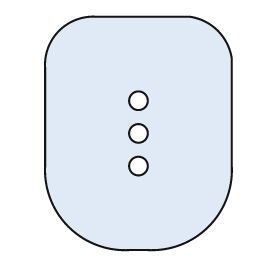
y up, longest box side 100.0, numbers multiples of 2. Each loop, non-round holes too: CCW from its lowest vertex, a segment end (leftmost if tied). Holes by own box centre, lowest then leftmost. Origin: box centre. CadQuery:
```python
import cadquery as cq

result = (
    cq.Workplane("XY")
    .moveTo(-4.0, -50.0)
    .lineTo(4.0, -50.0)
    .threePointArc((30.0, -40.0), (40.0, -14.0))
    .lineTo(40.0, 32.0)
    .threePointArc((34.0, 44.0), (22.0, 50.0))
    .lineTo(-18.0, 50.0)
    .threePointArc((-34.0, 44.0), (-40.0, 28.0))
    .lineTo(-40.0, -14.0)
    .threePointArc((-30.0, -40.0), (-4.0, -50.0))
    .close()
    .moveTo(0.0, -14.0)
    .circle(4.0)
    .moveTo(0.0, 0.0)
    .circle(4.0)
    .moveTo(0.0, 14.0)
    .circle(4.0)
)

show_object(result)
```